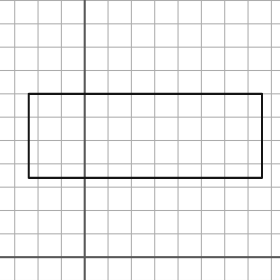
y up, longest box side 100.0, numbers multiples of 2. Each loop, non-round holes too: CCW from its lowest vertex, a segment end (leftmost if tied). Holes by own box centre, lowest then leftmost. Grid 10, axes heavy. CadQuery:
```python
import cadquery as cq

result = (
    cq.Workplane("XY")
    .moveTo(-24.0, 34.0)
    .lineTo(76.0, 34.0)
    .lineTo(76.0, 70.0)
    .lineTo(-24.0, 70.0)
    .close()
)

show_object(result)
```